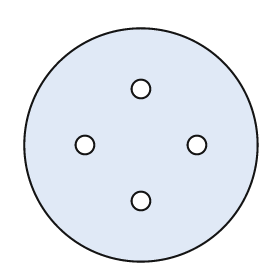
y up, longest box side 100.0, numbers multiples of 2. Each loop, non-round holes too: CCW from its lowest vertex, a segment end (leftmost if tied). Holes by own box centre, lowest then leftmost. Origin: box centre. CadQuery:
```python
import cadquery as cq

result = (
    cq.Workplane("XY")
    .moveTo(0.0, 0.0)
    .circle(50.0)
    .moveTo(0.0, -24.0)
    .circle(4.0)
    .moveTo(-24.0, 0.0)
    .circle(4.0)
    .moveTo(24.0, 0.0)
    .circle(4.0)
    .moveTo(0.0, 24.0)
    .circle(4.0)
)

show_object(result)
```